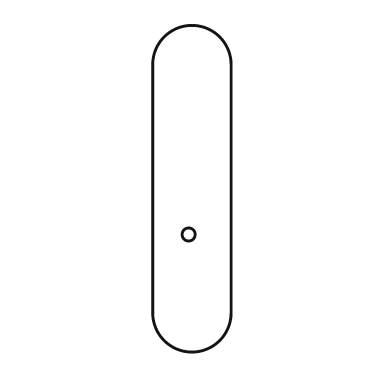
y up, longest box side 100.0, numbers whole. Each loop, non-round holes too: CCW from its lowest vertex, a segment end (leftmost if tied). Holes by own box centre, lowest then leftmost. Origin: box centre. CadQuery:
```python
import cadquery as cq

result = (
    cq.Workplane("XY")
    .moveTo(-12.0, -38.0)
    .threePointArc((0.0, -50.0), (12.0, -38.0))
    .lineTo(12.0, 38.0)
    .threePointArc((0.0, 50.0), (-12.0, 38.0))
    .close()
    .moveTo(-1.0, -14.0)
    .circle(2.0)
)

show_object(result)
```